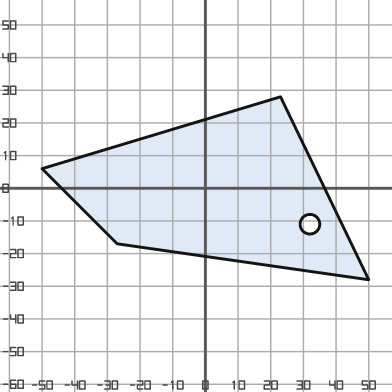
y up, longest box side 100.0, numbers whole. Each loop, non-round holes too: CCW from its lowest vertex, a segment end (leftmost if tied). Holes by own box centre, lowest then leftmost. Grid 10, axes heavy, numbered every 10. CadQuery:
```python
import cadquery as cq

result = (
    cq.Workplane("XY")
    .moveTo(50.0, -28.0)
    .lineTo(23.0, 28.0)
    .lineTo(-50.0, 6.0)
    .lineTo(-27.0, -17.0)
    .close()
    .moveTo(32.0, -11.0)
    .circle(3.0)
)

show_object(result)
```